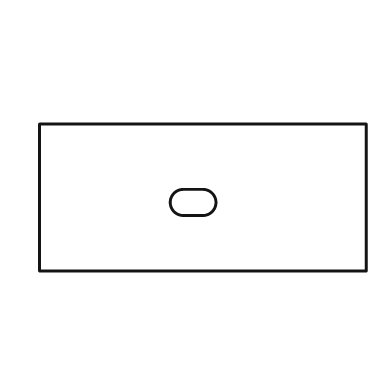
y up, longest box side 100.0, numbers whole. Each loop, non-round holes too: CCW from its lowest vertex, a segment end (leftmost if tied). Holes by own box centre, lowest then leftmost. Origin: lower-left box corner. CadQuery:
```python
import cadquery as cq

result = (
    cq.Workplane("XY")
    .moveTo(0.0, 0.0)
    .lineTo(100.0, 0.0)
    .lineTo(100.0, 45.0)
    .lineTo(0.0, 45.0)
    .close()
    .moveTo(44.0, 17.0)
    .lineTo(50.0, 17.0)
    .threePointArc((54.0, 21.0), (50.0, 25.0))
    .lineTo(44.0, 25.0)
    .threePointArc((40.0, 21.0), (44.0, 17.0))
    .close()
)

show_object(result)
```